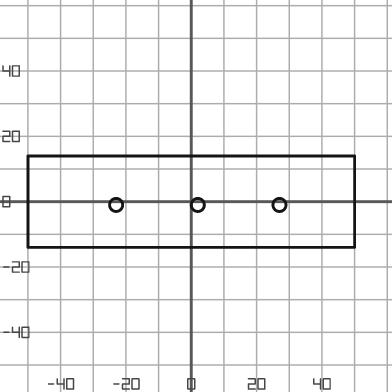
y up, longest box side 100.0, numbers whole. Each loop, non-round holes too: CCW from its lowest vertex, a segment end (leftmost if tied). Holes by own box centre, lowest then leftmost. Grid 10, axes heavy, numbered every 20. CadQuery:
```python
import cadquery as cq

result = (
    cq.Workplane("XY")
    .moveTo(-50.0, -14.0)
    .lineTo(50.0, -14.0)
    .lineTo(50.0, 14.0)
    .lineTo(-50.0, 14.0)
    .close()
    .moveTo(-23.0, -1.0)
    .circle(2.0)
    .moveTo(2.0, -1.0)
    .circle(2.0)
    .moveTo(27.0, -1.0)
    .circle(2.0)
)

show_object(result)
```